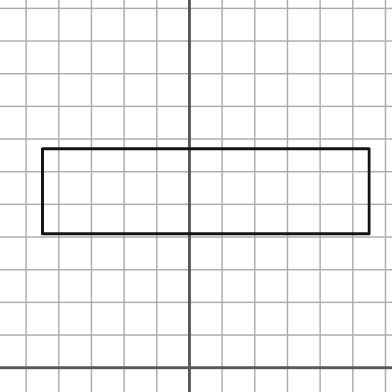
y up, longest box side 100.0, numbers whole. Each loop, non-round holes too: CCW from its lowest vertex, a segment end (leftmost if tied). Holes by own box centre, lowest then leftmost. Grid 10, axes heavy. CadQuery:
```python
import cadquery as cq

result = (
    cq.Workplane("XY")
    .moveTo(-45.0, 41.0)
    .lineTo(55.0, 41.0)
    .lineTo(55.0, 67.0)
    .lineTo(-45.0, 67.0)
    .close()
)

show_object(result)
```